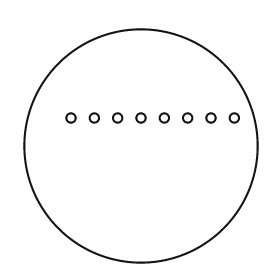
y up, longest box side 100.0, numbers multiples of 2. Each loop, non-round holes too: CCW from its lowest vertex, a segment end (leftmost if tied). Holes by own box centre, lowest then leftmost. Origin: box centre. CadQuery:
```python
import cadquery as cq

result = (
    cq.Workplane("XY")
    .moveTo(0.0, 0.0)
    .circle(50.0)
    .moveTo(-30.0, 12.0)
    .circle(2.0)
    .moveTo(-20.0, 12.0)
    .circle(2.0)
    .moveTo(-10.0, 12.0)
    .circle(2.0)
    .moveTo(0.0, 12.0)
    .circle(2.0)
    .moveTo(10.0, 12.0)
    .circle(2.0)
    .moveTo(20.0, 12.0)
    .circle(2.0)
    .moveTo(30.0, 12.0)
    .circle(2.0)
    .moveTo(40.0, 12.0)
    .circle(2.0)
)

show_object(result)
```